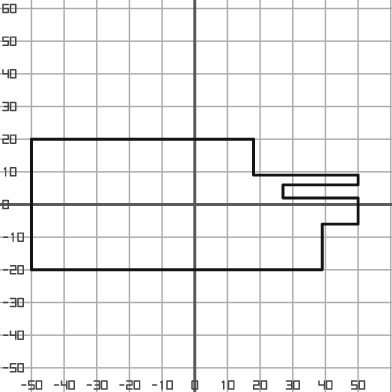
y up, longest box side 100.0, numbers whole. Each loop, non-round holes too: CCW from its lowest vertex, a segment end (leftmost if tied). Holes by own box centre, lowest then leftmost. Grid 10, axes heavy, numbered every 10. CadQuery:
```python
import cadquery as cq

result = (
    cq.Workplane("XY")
    .moveTo(-50.0, -20.0)
    .lineTo(39.0, -20.0)
    .lineTo(39.0, -6.0)
    .lineTo(50.0, -6.0)
    .lineTo(50.0, 2.0)
    .lineTo(27.0, 2.0)
    .lineTo(27.0, 6.0)
    .lineTo(50.0, 6.0)
    .lineTo(50.0, 9.0)
    .lineTo(18.0, 9.0)
    .lineTo(18.0, 20.0)
    .lineTo(-50.0, 20.0)
    .close()
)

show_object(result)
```